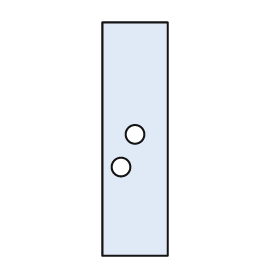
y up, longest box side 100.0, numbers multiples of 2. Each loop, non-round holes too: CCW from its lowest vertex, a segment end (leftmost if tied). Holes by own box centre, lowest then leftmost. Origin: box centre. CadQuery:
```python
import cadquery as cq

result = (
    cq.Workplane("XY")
    .moveTo(-14.0, -50.0)
    .lineTo(14.0, -50.0)
    .lineTo(14.0, 50.0)
    .lineTo(-14.0, 50.0)
    .close()
    .moveTo(-6.0, -12.0)
    .circle(4.0)
    .moveTo(0.0, 2.0)
    .circle(4.0)
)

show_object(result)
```